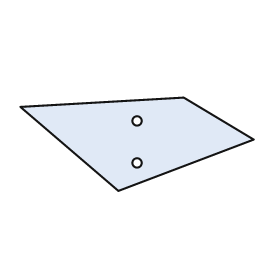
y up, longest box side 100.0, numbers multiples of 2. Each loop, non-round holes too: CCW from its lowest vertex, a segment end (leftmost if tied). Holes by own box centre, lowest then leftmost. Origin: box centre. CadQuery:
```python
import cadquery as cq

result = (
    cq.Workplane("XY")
    .moveTo(-8.0, -20.0)
    .lineTo(50.0, 2.0)
    .lineTo(20.0, 20.0)
    .lineTo(-50.0, 16.0)
    .close()
    .moveTo(0.0, -8.0)
    .circle(2.0)
    .moveTo(0.0, 10.0)
    .circle(2.0)
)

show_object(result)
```